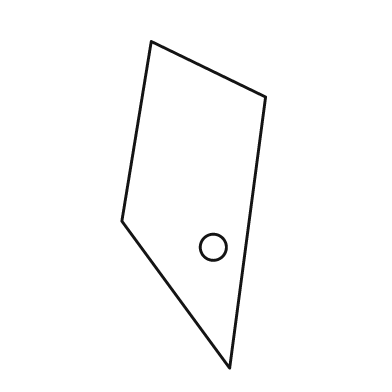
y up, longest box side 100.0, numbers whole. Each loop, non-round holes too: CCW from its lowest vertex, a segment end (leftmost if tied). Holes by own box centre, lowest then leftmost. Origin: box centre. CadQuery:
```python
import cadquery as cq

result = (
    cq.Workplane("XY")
    .moveTo(11.0, -50.0)
    .lineTo(22.0, 33.0)
    .lineTo(-13.0, 50.0)
    .lineTo(-22.0, -5.0)
    .close()
    .moveTo(6.0, -13.0)
    .circle(4.0)
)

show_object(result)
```